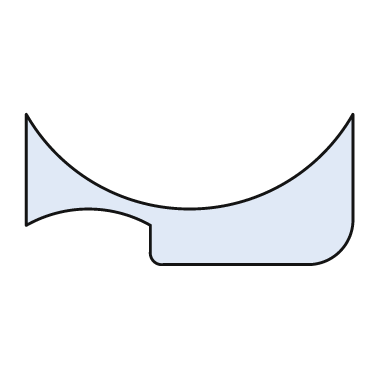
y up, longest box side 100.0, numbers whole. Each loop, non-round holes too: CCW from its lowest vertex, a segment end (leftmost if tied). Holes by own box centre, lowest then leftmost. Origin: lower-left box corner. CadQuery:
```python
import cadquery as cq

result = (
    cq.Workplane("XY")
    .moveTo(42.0, 0.0)
    .lineTo(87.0, 0.0)
    .threePointArc((96.0, 4.0), (100.0, 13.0))
    .lineTo(100.0, 46.0)
    .threePointArc((50.0, 17.0), (0.0, 46.0))
    .lineTo(0.0, 12.0)
    .threePointArc((19.0, 17.0), (38.0, 12.0))
    .lineTo(38.0, 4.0)
    .threePointArc((39.0, 1.0), (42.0, 0.0))
    .close()
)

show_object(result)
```